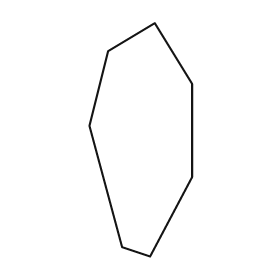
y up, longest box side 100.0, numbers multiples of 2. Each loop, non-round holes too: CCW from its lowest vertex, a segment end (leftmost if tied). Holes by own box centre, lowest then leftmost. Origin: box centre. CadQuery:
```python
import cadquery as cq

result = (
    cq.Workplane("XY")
    .moveTo(4.0, -50.0)
    .lineTo(22.0, -16.0)
    .lineTo(22.0, 24.0)
    .lineTo(6.0, 50.0)
    .lineTo(-14.0, 38.0)
    .lineTo(-22.0, 6.0)
    .lineTo(-8.0, -46.0)
    .close()
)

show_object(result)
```